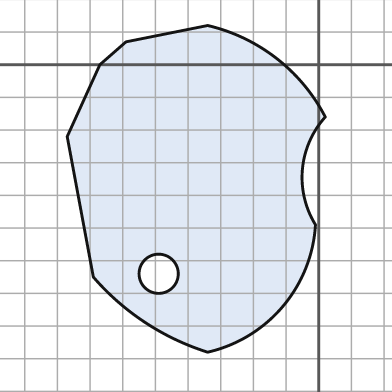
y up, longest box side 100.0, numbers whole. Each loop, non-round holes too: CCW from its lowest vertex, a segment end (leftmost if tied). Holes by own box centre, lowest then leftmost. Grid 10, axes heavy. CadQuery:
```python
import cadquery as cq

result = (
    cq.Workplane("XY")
    .moveTo(-34.0, -88.0)
    .threePointArc((-11.0, -74.0), (-1.0, -49.0))
    .threePointArc((-5.0, -32.0), (2.0, -16.0))
    .threePointArc((-13.0, 2.0), (-34.0, 12.0))
    .lineTo(-59.0, 7.0)
    .lineTo(-67.0, 0.0)
    .lineTo(-77.0, -22.0)
    .lineTo(-69.0, -65.0)
    .threePointArc((-53.0, -79.0), (-34.0, -88.0))
    .close()
    .moveTo(-49.0, -64.0)
    .circle(6.0)
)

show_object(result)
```